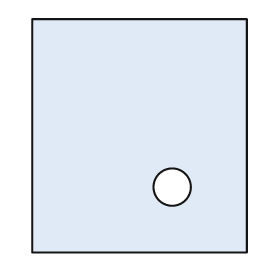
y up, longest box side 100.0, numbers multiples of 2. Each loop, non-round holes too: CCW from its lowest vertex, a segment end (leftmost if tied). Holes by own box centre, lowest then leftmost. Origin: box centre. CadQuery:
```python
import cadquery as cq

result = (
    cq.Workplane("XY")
    .moveTo(-46.0, -50.0)
    .lineTo(46.0, -50.0)
    .lineTo(46.0, 50.0)
    .lineTo(-46.0, 50.0)
    .close()
    .moveTo(14.0, -22.0)
    .circle(8.0)
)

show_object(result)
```